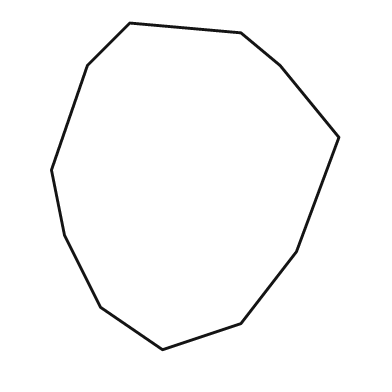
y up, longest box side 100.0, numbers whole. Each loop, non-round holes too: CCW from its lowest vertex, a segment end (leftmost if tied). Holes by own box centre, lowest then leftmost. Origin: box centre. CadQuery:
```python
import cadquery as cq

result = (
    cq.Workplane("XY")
    .moveTo(-10.0, -50.0)
    .lineTo(14.0, -42.0)
    .lineTo(31.0, -20.0)
    .lineTo(44.0, 15.0)
    .lineTo(26.0, 37.0)
    .lineTo(14.0, 47.0)
    .lineTo(-20.0, 50.0)
    .lineTo(-33.0, 37.0)
    .lineTo(-44.0, 5.0)
    .lineTo(-40.0, -15.0)
    .lineTo(-29.0, -37.0)
    .close()
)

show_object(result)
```